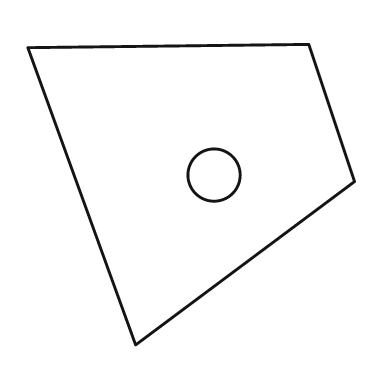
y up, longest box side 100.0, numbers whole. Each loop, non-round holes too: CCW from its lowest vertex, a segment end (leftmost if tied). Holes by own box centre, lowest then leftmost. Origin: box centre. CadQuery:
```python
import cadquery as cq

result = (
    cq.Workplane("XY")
    .moveTo(-17.0, -46.0)
    .lineTo(50.0, 4.0)
    .lineTo(36.0, 46.0)
    .lineTo(-50.0, 45.0)
    .close()
    .moveTo(7.0, 6.0)
    .circle(8.0)
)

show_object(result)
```